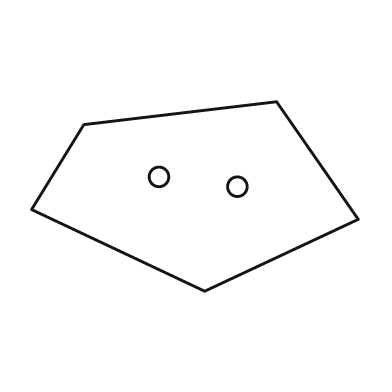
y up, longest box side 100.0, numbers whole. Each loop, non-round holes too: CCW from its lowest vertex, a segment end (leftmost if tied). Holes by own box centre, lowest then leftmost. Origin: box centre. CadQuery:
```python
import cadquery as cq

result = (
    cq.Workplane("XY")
    .moveTo(3.0, -29.0)
    .lineTo(50.0, -7.0)
    .lineTo(25.0, 29.0)
    .lineTo(-34.0, 22.0)
    .lineTo(-50.0, -4.0)
    .close()
    .moveTo(13.0, 3.0)
    .circle(3.0)
    .moveTo(-11.0, 6.0)
    .circle(3.0)
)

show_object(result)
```